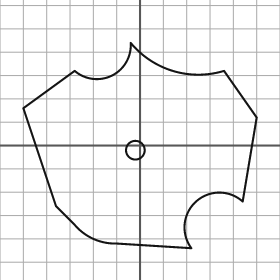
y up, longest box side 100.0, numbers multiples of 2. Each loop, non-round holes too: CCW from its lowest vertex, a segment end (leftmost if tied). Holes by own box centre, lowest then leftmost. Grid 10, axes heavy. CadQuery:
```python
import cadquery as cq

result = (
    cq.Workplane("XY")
    .moveTo(22.0, -44.0)
    .threePointArc((24.0, -24.0), (44.0, -24.0))
    .lineTo(50.0, 12.0)
    .lineTo(36.0, 32.0)
    .threePointArc((14.0, 32.0), (-4.0, 44.0))
    .threePointArc((-12.0, 30.0), (-28.0, 32.0))
    .lineTo(-50.0, 16.0)
    .lineTo(-36.0, -26.0)
    .lineTo(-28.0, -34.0)
    .threePointArc((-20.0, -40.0), (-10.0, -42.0))
    .close()
    .moveTo(-2.0, -2.0)
    .circle(4.0)
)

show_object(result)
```